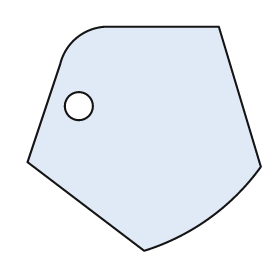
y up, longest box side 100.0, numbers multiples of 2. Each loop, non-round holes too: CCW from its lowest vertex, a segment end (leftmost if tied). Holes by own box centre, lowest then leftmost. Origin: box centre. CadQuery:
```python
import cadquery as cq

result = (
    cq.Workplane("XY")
    .moveTo(0.0, -48.0)
    .threePointArc((28.0, -34.0), (50.0, -12.0))
    .lineTo(32.0, 48.0)
    .lineTo(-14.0, 48.0)
    .threePointArc((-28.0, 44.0), (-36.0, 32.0))
    .lineTo(-50.0, -10.0)
    .close()
    .moveTo(-28.0, 14.0)
    .circle(6.0)
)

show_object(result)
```